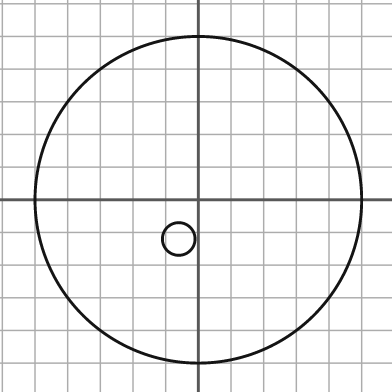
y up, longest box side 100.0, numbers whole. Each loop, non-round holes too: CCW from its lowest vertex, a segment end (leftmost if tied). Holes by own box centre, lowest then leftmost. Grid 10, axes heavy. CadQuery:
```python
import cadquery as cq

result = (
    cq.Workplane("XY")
    .moveTo(0.0, 0.0)
    .circle(50.0)
    .moveTo(-6.0, -12.0)
    .circle(5.0)
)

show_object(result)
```